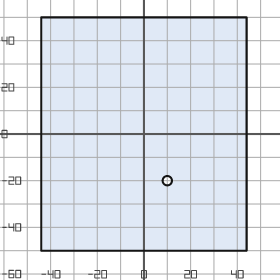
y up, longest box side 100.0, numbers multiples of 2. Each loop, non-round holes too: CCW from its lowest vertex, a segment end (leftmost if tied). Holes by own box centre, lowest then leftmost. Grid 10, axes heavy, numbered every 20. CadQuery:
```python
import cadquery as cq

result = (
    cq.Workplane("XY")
    .moveTo(-44.0, -50.0)
    .lineTo(44.0, -50.0)
    .lineTo(44.0, 50.0)
    .lineTo(-44.0, 50.0)
    .close()
    .moveTo(10.0, -20.0)
    .circle(2.0)
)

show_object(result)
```